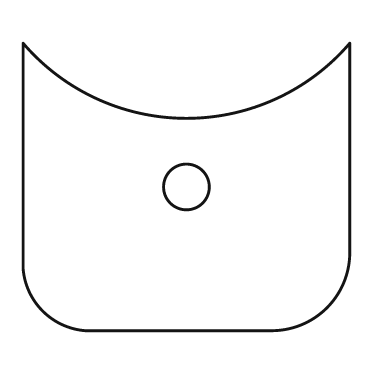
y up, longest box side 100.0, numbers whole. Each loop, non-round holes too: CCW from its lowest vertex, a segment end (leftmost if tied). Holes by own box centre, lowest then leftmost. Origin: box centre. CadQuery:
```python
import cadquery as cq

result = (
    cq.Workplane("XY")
    .moveTo(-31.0, -44.0)
    .lineTo(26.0, -44.0)
    .threePointArc((43.0, -37.0), (50.0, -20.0))
    .lineTo(50.0, 44.0)
    .threePointArc((0.0, 21.0), (-50.0, 44.0))
    .lineTo(-50.0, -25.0)
    .threePointArc((-44.0, -38.0), (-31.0, -44.0))
    .close()
    .moveTo(0.0, 0.0)
    .circle(7.0)
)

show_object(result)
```